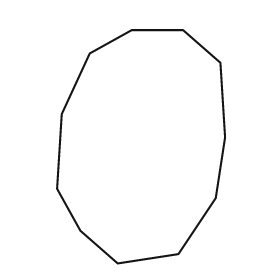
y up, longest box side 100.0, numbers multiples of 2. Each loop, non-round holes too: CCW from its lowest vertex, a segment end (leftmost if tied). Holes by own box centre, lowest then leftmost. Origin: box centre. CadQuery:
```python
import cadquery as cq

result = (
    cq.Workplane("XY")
    .moveTo(-10.0, -50.0)
    .lineTo(16.0, -46.0)
    .lineTo(32.0, -22.0)
    .lineTo(36.0, 4.0)
    .lineTo(34.0, 36.0)
    .lineTo(18.0, 50.0)
    .lineTo(-4.0, 50.0)
    .lineTo(-22.0, 40.0)
    .lineTo(-34.0, 14.0)
    .lineTo(-36.0, -18.0)
    .lineTo(-26.0, -36.0)
    .close()
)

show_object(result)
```